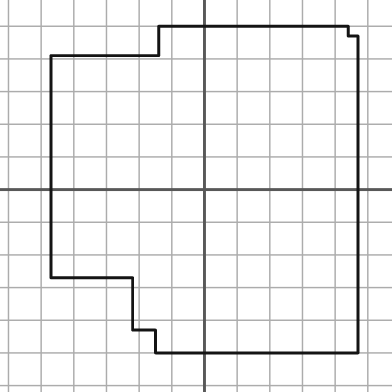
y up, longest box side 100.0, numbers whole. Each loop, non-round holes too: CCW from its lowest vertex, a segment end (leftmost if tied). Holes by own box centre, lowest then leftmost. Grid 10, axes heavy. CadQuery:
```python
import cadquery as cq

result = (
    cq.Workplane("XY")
    .moveTo(-15.0, -50.0)
    .lineTo(47.0, -50.0)
    .lineTo(47.0, 47.0)
    .lineTo(44.0, 47.0)
    .lineTo(44.0, 50.0)
    .lineTo(-14.0, 50.0)
    .lineTo(-14.0, 41.0)
    .lineTo(-47.0, 41.0)
    .lineTo(-47.0, -27.0)
    .lineTo(-22.0, -27.0)
    .lineTo(-22.0, -43.0)
    .lineTo(-15.0, -43.0)
    .close()
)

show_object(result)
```